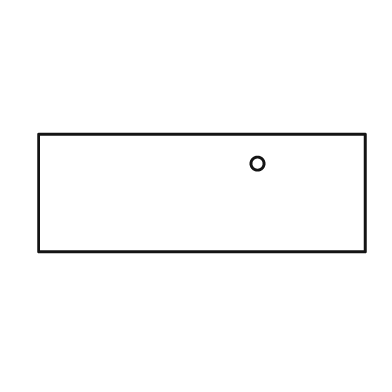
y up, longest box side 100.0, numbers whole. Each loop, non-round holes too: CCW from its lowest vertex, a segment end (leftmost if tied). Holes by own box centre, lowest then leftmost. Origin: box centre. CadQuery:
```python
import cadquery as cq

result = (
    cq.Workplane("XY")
    .moveTo(-50.0, -18.0)
    .lineTo(50.0, -18.0)
    .lineTo(50.0, 18.0)
    .lineTo(-50.0, 18.0)
    .close()
    .moveTo(17.0, 9.0)
    .circle(2.0)
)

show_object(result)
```